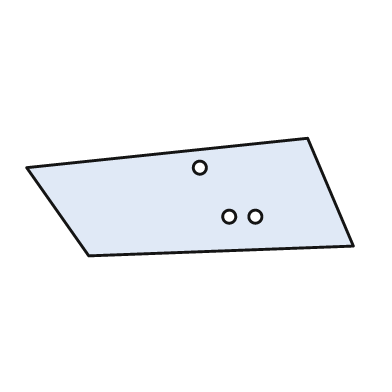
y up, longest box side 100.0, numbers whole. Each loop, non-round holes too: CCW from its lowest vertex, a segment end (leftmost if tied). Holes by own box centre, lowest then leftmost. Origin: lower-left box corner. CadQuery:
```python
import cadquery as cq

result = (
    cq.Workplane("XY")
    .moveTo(19.0, 0.0)
    .lineTo(100.0, 3.0)
    .lineTo(86.0, 36.0)
    .lineTo(0.0, 27.0)
    .close()
    .moveTo(62.0, 12.0)
    .circle(2.0)
    .moveTo(70.0, 12.0)
    .circle(2.0)
    .moveTo(53.0, 27.0)
    .circle(2.0)
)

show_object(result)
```